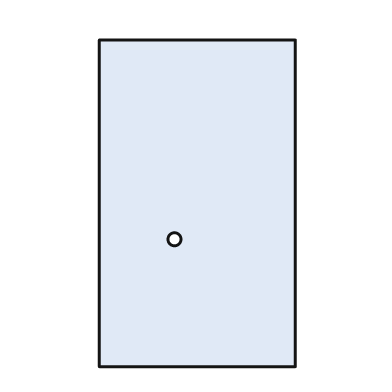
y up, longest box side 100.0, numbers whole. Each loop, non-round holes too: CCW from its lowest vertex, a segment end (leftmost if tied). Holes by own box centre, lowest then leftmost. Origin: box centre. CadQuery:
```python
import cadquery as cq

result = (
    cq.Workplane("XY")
    .moveTo(-30.0, -50.0)
    .lineTo(30.0, -50.0)
    .lineTo(30.0, 50.0)
    .lineTo(-30.0, 50.0)
    .close()
    .moveTo(-7.0, -11.0)
    .circle(2.0)
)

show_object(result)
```